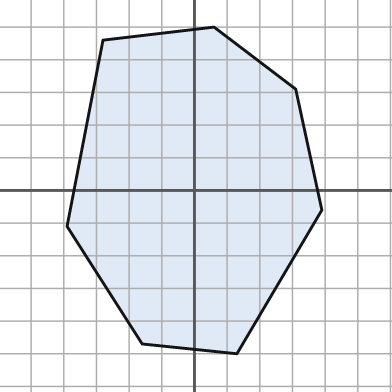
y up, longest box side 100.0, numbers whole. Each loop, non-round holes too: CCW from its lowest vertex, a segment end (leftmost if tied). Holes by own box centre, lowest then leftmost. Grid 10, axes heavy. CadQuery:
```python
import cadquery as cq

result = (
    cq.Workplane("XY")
    .moveTo(13.0, -50.0)
    .lineTo(39.0, -6.0)
    .lineTo(31.0, 31.0)
    .lineTo(6.0, 50.0)
    .lineTo(-28.0, 46.0)
    .lineTo(-39.0, -11.0)
    .lineTo(-16.0, -47.0)
    .close()
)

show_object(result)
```